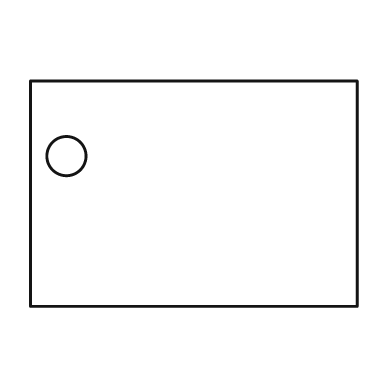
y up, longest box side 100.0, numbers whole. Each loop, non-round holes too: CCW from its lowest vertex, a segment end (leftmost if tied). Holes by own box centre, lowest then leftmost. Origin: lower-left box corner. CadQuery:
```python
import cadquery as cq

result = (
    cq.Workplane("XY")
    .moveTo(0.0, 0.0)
    .lineTo(100.0, 0.0)
    .lineTo(100.0, 69.0)
    .lineTo(0.0, 69.0)
    .close()
    .moveTo(11.0, 46.0)
    .circle(6.0)
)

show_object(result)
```